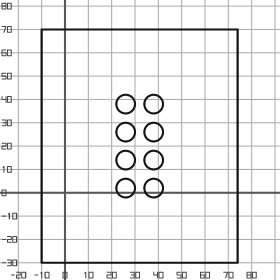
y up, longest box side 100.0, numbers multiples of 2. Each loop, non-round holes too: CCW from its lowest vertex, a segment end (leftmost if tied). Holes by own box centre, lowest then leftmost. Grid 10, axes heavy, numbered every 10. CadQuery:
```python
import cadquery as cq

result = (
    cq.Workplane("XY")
    .moveTo(-10.0, -30.0)
    .lineTo(74.0, -30.0)
    .lineTo(74.0, 70.0)
    .lineTo(-10.0, 70.0)
    .close()
    .moveTo(26.0, 2.0)
    .circle(4.0)
    .moveTo(38.0, 2.0)
    .circle(4.0)
    .moveTo(26.0, 14.0)
    .circle(4.0)
    .moveTo(38.0, 14.0)
    .circle(4.0)
    .moveTo(26.0, 26.0)
    .circle(4.0)
    .moveTo(38.0, 26.0)
    .circle(4.0)
    .moveTo(26.0, 38.0)
    .circle(4.0)
    .moveTo(38.0, 38.0)
    .circle(4.0)
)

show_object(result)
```